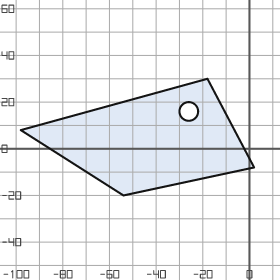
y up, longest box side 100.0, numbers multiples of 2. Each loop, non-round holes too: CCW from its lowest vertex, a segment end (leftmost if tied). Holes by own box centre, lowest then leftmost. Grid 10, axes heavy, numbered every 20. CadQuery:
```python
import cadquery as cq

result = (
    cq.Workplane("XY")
    .moveTo(-54.0, -20.0)
    .lineTo(2.0, -8.0)
    .lineTo(-18.0, 30.0)
    .lineTo(-98.0, 8.0)
    .close()
    .moveTo(-26.0, 16.0)
    .circle(4.0)
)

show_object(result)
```